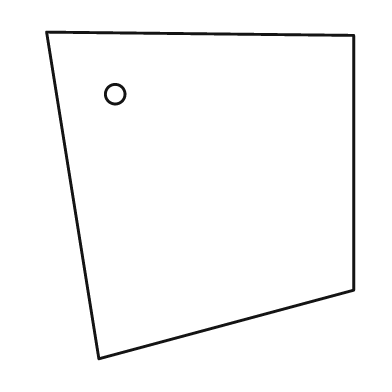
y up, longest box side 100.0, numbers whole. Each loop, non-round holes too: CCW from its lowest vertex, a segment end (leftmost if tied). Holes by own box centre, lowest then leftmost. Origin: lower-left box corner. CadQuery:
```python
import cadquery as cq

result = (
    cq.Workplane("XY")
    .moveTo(16.0, 0.0)
    .lineTo(94.0, 21.0)
    .lineTo(94.0, 99.0)
    .lineTo(0.0, 100.0)
    .close()
    .moveTo(21.0, 81.0)
    .circle(3.0)
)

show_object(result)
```